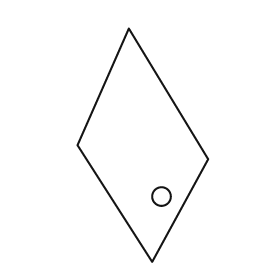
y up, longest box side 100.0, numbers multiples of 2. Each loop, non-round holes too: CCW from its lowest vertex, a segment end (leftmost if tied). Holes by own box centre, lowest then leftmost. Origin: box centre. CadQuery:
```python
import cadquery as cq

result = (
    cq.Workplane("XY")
    .moveTo(4.0, -50.0)
    .lineTo(28.0, -6.0)
    .lineTo(-6.0, 50.0)
    .lineTo(-28.0, 0.0)
    .close()
    .moveTo(8.0, -22.0)
    .circle(4.0)
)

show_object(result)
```